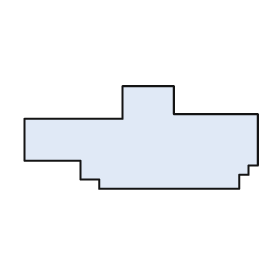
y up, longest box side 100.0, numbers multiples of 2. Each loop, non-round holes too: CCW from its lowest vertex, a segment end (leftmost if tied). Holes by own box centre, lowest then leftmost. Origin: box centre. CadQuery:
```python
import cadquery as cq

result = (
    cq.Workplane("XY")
    .moveTo(-18.0, -22.0)
    .lineTo(42.0, -22.0)
    .lineTo(42.0, -16.0)
    .lineTo(46.0, -16.0)
    .lineTo(46.0, -12.0)
    .lineTo(50.0, -12.0)
    .lineTo(50.0, 10.0)
    .lineTo(14.0, 10.0)
    .lineTo(14.0, 22.0)
    .lineTo(-8.0, 22.0)
    .lineTo(-8.0, 8.0)
    .lineTo(-50.0, 8.0)
    .lineTo(-50.0, -10.0)
    .lineTo(-26.0, -10.0)
    .lineTo(-26.0, -18.0)
    .lineTo(-18.0, -18.0)
    .close()
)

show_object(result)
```